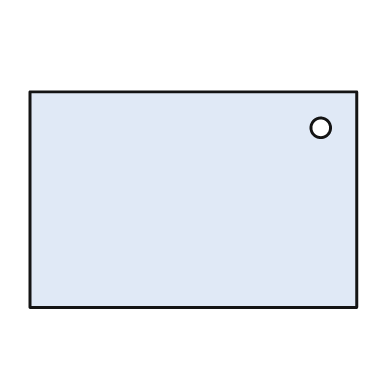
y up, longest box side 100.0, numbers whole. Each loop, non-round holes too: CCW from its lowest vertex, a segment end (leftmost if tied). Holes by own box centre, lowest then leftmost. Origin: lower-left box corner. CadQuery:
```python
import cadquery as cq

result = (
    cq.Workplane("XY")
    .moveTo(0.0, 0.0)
    .lineTo(100.0, 0.0)
    .lineTo(100.0, 66.0)
    .lineTo(0.0, 66.0)
    .close()
    .moveTo(89.0, 55.0)
    .circle(3.0)
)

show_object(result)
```